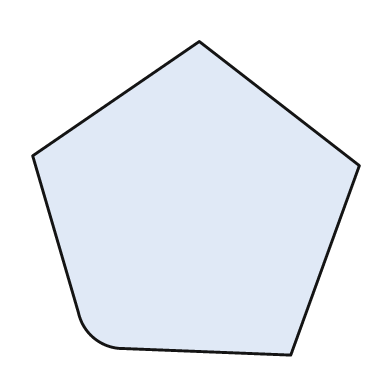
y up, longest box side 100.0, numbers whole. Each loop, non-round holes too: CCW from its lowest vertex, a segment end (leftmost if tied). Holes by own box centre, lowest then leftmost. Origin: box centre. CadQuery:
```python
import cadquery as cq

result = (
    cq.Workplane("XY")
    .moveTo(29.0, -48.0)
    .lineTo(50.0, 10.0)
    .lineTo(1.0, 48.0)
    .lineTo(-50.0, 13.0)
    .lineTo(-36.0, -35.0)
    .threePointArc((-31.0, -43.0), (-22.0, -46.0))
    .close()
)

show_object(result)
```